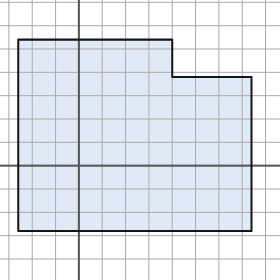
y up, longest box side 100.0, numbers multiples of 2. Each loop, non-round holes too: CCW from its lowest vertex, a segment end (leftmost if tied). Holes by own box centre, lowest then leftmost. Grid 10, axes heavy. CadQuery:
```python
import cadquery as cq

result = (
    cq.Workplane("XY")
    .moveTo(-26.0, -28.0)
    .lineTo(74.0, -28.0)
    .lineTo(74.0, 38.0)
    .lineTo(40.0, 38.0)
    .lineTo(40.0, 54.0)
    .lineTo(-26.0, 54.0)
    .close()
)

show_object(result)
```